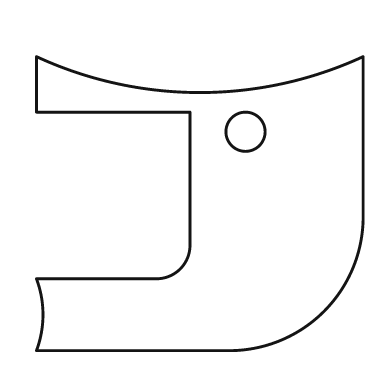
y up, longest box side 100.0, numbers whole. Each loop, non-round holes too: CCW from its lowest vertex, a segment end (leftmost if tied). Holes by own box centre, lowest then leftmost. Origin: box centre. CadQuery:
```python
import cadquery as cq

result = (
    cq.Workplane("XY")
    .moveTo(-50.0, -45.0)
    .lineTo(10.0, -45.0)
    .threePointArc((38.0, -33.0), (50.0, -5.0))
    .lineTo(50.0, 45.0)
    .threePointArc((0.0, 34.0), (-50.0, 45.0))
    .lineTo(-50.0, 28.0)
    .lineTo(-3.0, 28.0)
    .lineTo(-3.0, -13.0)
    .threePointArc((-6.0, -20.0), (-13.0, -23.0))
    .lineTo(-50.0, -23.0)
    .threePointArc((-48.0, -34.0), (-50.0, -45.0))
    .close()
    .moveTo(14.0, 22.0)
    .circle(6.0)
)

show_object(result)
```